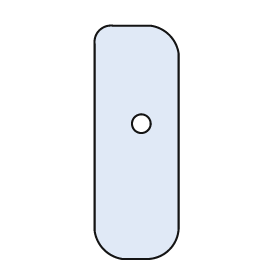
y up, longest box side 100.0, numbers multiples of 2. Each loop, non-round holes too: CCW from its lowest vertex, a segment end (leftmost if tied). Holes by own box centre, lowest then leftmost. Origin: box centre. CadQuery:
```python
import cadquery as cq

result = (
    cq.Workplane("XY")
    .moveTo(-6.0, -50.0)
    .lineTo(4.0, -50.0)
    .threePointArc((14.0, -46.0), (18.0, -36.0))
    .lineTo(18.0, 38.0)
    .threePointArc((14.0, 46.0), (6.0, 50.0))
    .lineTo(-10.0, 50.0)
    .threePointArc((-16.0, 48.0), (-18.0, 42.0))
    .lineTo(-18.0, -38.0)
    .threePointArc((-14.0, -46.0), (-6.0, -50.0))
    .close()
    .moveTo(2.0, 8.0)
    .circle(4.0)
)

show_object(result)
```